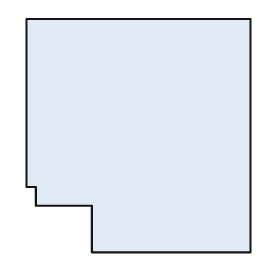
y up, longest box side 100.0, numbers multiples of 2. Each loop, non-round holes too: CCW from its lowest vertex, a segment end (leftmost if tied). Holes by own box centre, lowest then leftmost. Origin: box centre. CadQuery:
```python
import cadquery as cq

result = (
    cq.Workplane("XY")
    .moveTo(-20.0, -50.0)
    .lineTo(48.0, -50.0)
    .lineTo(48.0, 50.0)
    .lineTo(-48.0, 50.0)
    .lineTo(-48.0, -22.0)
    .lineTo(-44.0, -22.0)
    .lineTo(-44.0, -30.0)
    .lineTo(-20.0, -30.0)
    .close()
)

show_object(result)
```